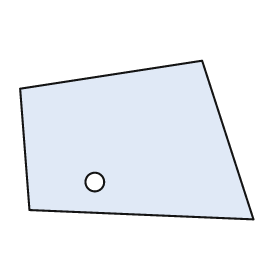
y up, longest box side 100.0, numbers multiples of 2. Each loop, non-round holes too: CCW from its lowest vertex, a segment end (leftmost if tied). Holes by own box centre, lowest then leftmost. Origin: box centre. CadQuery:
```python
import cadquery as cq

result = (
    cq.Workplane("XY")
    .moveTo(50.0, -34.0)
    .lineTo(28.0, 34.0)
    .lineTo(-50.0, 22.0)
    .lineTo(-46.0, -30.0)
    .close()
    .moveTo(-18.0, -18.0)
    .circle(4.0)
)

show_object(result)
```